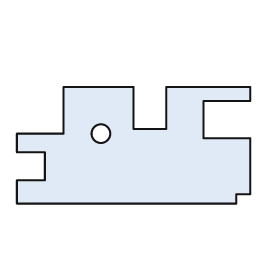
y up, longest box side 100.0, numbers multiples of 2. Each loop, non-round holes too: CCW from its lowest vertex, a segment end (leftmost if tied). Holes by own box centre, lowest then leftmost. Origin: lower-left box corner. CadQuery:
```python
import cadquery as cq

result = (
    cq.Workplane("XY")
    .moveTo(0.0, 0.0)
    .lineTo(94.0, 0.0)
    .lineTo(94.0, 4.0)
    .lineTo(100.0, 4.0)
    .lineTo(100.0, 28.0)
    .lineTo(80.0, 28.0)
    .lineTo(80.0, 44.0)
    .lineTo(100.0, 44.0)
    .lineTo(100.0, 50.0)
    .lineTo(64.0, 50.0)
    .lineTo(64.0, 32.0)
    .lineTo(50.0, 32.0)
    .lineTo(50.0, 50.0)
    .lineTo(20.0, 50.0)
    .lineTo(20.0, 30.0)
    .lineTo(0.0, 30.0)
    .lineTo(0.0, 22.0)
    .lineTo(12.0, 22.0)
    .lineTo(12.0, 10.0)
    .lineTo(0.0, 10.0)
    .close()
    .moveTo(36.0, 30.0)
    .circle(4.0)
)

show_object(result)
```